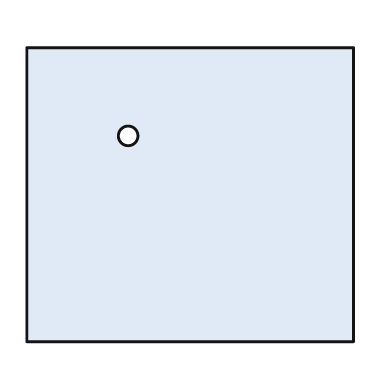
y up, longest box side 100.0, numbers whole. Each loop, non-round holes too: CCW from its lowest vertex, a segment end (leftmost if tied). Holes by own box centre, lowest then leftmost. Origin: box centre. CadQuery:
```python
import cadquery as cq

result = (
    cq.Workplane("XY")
    .moveTo(-50.0, -45.0)
    .lineTo(50.0, -45.0)
    .lineTo(50.0, 45.0)
    .lineTo(-50.0, 45.0)
    .close()
    .moveTo(-19.0, 18.0)
    .circle(3.0)
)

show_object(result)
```